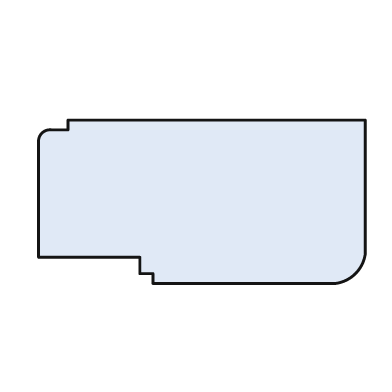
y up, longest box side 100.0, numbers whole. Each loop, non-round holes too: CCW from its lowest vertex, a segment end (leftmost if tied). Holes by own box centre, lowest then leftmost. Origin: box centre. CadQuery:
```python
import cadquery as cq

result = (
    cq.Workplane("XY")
    .moveTo(-15.0, -25.0)
    .lineTo(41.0, -25.0)
    .threePointArc((47.0, -22.0), (50.0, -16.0))
    .lineTo(50.0, 25.0)
    .lineTo(-41.0, 25.0)
    .lineTo(-41.0, 22.0)
    .lineTo(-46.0, 22.0)
    .threePointArc((-49.0, 21.0), (-50.0, 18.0))
    .lineTo(-50.0, -17.0)
    .lineTo(-19.0, -17.0)
    .lineTo(-19.0, -22.0)
    .lineTo(-15.0, -22.0)
    .close()
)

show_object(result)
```